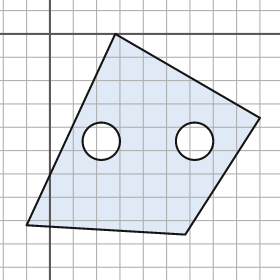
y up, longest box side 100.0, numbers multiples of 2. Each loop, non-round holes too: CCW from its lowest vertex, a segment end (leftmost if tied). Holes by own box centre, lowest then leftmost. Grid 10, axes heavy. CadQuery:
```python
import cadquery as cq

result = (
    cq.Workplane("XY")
    .moveTo(58.0, -86.0)
    .lineTo(90.0, -36.0)
    .lineTo(28.0, 0.0)
    .lineTo(-10.0, -82.0)
    .close()
    .moveTo(22.0, -46.0)
    .circle(8.0)
    .moveTo(62.0, -46.0)
    .circle(8.0)
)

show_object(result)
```